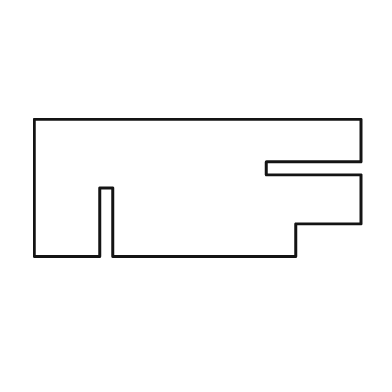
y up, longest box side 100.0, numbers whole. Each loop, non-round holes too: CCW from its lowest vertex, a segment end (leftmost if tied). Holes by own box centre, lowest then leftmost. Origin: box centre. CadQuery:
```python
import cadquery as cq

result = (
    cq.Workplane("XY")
    .moveTo(-50.0, -21.0)
    .lineTo(-30.0, -21.0)
    .lineTo(-30.0, 0.0)
    .lineTo(-26.0, 0.0)
    .lineTo(-26.0, -21.0)
    .lineTo(30.0, -21.0)
    .lineTo(30.0, -11.0)
    .lineTo(50.0, -11.0)
    .lineTo(50.0, 4.0)
    .lineTo(21.0, 4.0)
    .lineTo(21.0, 8.0)
    .lineTo(50.0, 8.0)
    .lineTo(50.0, 21.0)
    .lineTo(-50.0, 21.0)
    .close()
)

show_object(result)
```